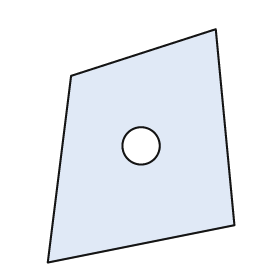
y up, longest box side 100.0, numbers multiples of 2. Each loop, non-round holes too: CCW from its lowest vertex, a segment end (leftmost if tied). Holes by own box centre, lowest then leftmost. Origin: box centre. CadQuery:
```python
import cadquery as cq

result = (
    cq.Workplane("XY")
    .moveTo(-40.0, -50.0)
    .lineTo(40.0, -34.0)
    .lineTo(32.0, 50.0)
    .lineTo(-30.0, 30.0)
    .close()
    .moveTo(0.0, 0.0)
    .circle(8.0)
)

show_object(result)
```